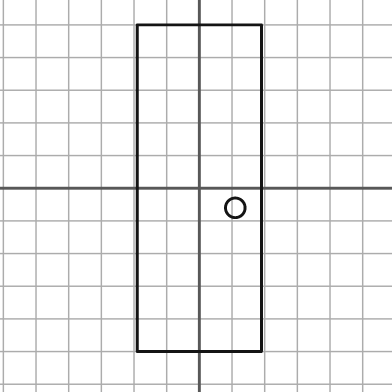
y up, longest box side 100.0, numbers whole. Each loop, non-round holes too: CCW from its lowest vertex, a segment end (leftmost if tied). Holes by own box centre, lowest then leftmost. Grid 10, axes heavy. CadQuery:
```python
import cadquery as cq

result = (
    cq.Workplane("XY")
    .moveTo(-19.0, -50.0)
    .lineTo(19.0, -50.0)
    .lineTo(19.0, 50.0)
    .lineTo(-19.0, 50.0)
    .close()
    .moveTo(11.0, -6.0)
    .circle(3.0)
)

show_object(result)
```